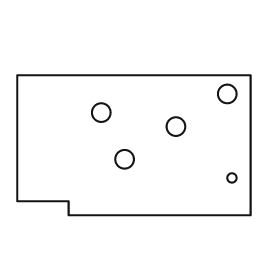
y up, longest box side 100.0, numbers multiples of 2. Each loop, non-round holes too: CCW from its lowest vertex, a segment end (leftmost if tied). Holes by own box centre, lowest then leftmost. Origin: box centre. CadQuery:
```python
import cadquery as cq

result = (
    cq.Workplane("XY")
    .moveTo(-28.0, -30.0)
    .lineTo(50.0, -30.0)
    .lineTo(50.0, 30.0)
    .lineTo(-50.0, 30.0)
    .lineTo(-50.0, -24.0)
    .lineTo(-28.0, -24.0)
    .close()
    .moveTo(42.0, -14.0)
    .circle(2.0)
    .moveTo(-4.0, -6.0)
    .circle(4.0)
    .moveTo(18.0, 8.0)
    .circle(4.0)
    .moveTo(-14.0, 14.0)
    .circle(4.0)
    .moveTo(40.0, 22.0)
    .circle(4.0)
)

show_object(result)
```